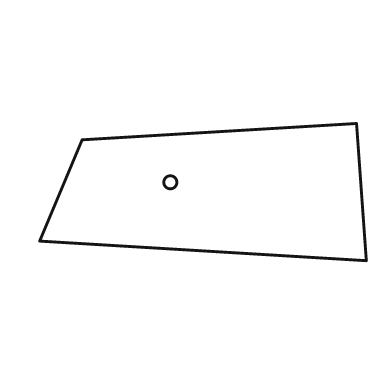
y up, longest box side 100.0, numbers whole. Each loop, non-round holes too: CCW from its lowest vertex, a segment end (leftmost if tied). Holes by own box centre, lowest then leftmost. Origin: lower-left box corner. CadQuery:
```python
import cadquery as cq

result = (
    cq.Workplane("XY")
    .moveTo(100.0, 0.0)
    .lineTo(97.0, 42.0)
    .lineTo(13.0, 37.0)
    .lineTo(0.0, 6.0)
    .close()
    .moveTo(40.0, 24.0)
    .circle(2.0)
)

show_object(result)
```